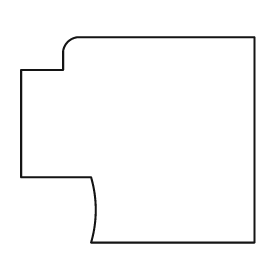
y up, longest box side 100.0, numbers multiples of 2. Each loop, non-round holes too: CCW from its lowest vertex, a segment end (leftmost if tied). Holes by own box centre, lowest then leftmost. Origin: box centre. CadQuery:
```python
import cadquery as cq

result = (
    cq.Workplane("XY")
    .moveTo(-20.0, -44.0)
    .lineTo(50.0, -44.0)
    .lineTo(50.0, 44.0)
    .lineTo(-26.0, 44.0)
    .threePointArc((-30.0, 42.0), (-32.0, 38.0))
    .lineTo(-32.0, 30.0)
    .lineTo(-50.0, 30.0)
    .lineTo(-50.0, -16.0)
    .lineTo(-20.0, -16.0)
    .threePointArc((-18.0, -30.0), (-20.0, -44.0))
    .close()
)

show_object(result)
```